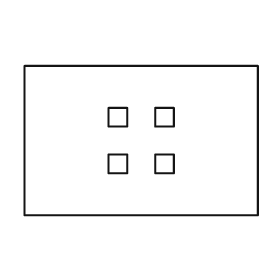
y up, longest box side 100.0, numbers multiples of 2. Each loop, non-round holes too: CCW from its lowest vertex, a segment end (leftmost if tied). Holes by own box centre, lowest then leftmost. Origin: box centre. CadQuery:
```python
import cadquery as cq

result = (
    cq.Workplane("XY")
    .moveTo(-50.0, -32.0)
    .lineTo(50.0, -32.0)
    .lineTo(50.0, 32.0)
    .lineTo(-50.0, 32.0)
    .close()
    .moveTo(-14.0, -14.0)
    .lineTo(-6.0, -14.0)
    .lineTo(-6.0, -6.0)
    .lineTo(-14.0, -6.0)
    .close()
    .moveTo(6.0, -14.0)
    .lineTo(14.0, -14.0)
    .lineTo(14.0, -6.0)
    .lineTo(6.0, -6.0)
    .close()
    .moveTo(-14.0, 6.0)
    .lineTo(-6.0, 6.0)
    .lineTo(-6.0, 14.0)
    .lineTo(-14.0, 14.0)
    .close()
    .moveTo(6.0, 6.0)
    .lineTo(14.0, 6.0)
    .lineTo(14.0, 14.0)
    .lineTo(6.0, 14.0)
    .close()
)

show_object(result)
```